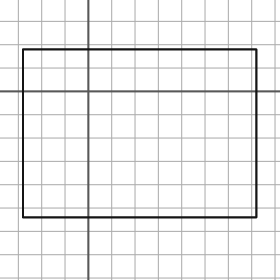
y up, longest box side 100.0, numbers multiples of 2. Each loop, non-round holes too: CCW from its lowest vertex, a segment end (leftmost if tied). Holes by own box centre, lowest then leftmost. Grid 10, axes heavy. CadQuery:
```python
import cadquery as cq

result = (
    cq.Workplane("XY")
    .moveTo(-28.0, -54.0)
    .lineTo(72.0, -54.0)
    .lineTo(72.0, 18.0)
    .lineTo(-28.0, 18.0)
    .close()
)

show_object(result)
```